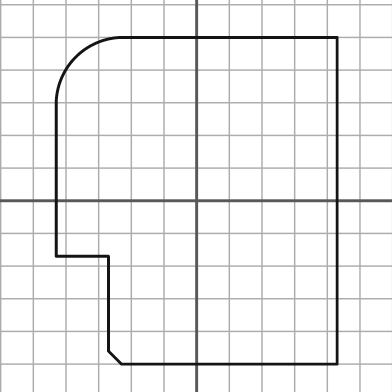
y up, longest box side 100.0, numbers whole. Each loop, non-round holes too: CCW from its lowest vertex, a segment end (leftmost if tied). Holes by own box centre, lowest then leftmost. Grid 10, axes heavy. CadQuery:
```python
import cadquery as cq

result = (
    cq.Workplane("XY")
    .moveTo(-23.0, -50.0)
    .lineTo(43.0, -50.0)
    .lineTo(43.0, 50.0)
    .lineTo(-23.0, 50.0)
    .threePointArc((-37.0, 44.0), (-43.0, 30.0))
    .lineTo(-43.0, -17.0)
    .lineTo(-27.0, -17.0)
    .lineTo(-27.0, -46.0)
    .close()
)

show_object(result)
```